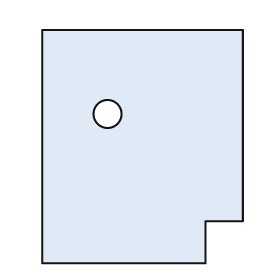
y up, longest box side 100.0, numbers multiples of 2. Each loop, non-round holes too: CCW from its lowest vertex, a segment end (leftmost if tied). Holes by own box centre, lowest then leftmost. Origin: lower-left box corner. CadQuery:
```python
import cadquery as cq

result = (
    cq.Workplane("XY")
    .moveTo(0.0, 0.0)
    .lineTo(70.0, 0.0)
    .lineTo(70.0, 18.0)
    .lineTo(86.0, 18.0)
    .lineTo(86.0, 100.0)
    .lineTo(0.0, 100.0)
    .close()
    .moveTo(28.0, 64.0)
    .circle(6.0)
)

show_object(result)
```